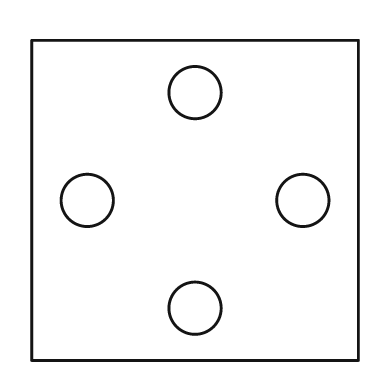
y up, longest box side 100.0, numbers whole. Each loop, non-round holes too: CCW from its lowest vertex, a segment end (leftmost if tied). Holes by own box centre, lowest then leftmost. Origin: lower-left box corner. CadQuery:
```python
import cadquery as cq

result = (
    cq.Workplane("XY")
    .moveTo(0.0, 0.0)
    .lineTo(100.0, 0.0)
    .lineTo(100.0, 98.0)
    .lineTo(0.0, 98.0)
    .close()
    .moveTo(50.0, 16.0)
    .circle(8.0)
    .moveTo(17.0, 49.0)
    .circle(8.0)
    .moveTo(83.0, 49.0)
    .circle(8.0)
    .moveTo(50.0, 82.0)
    .circle(8.0)
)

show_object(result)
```